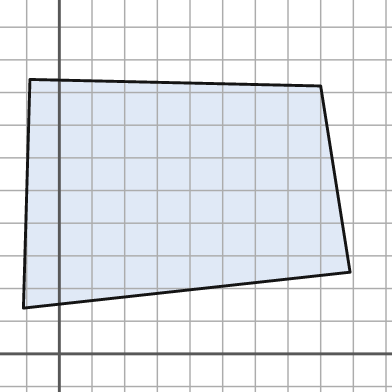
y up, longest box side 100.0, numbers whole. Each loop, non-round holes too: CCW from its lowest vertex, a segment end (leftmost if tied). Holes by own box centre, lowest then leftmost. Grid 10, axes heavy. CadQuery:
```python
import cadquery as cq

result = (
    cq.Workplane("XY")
    .moveTo(-11.0, 14.0)
    .lineTo(89.0, 25.0)
    .lineTo(80.0, 82.0)
    .lineTo(-9.0, 84.0)
    .close()
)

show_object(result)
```